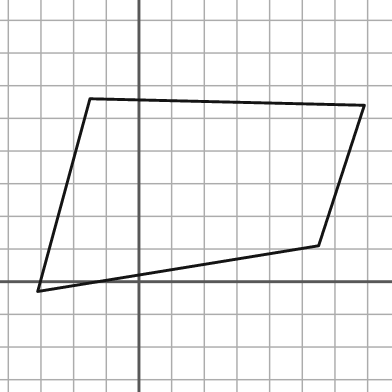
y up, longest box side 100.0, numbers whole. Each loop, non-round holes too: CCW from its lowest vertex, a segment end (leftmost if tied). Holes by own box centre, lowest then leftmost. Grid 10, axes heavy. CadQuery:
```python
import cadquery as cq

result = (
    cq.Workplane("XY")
    .moveTo(-31.0, -3.0)
    .lineTo(55.0, 11.0)
    .lineTo(69.0, 54.0)
    .lineTo(-15.0, 56.0)
    .close()
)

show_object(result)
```